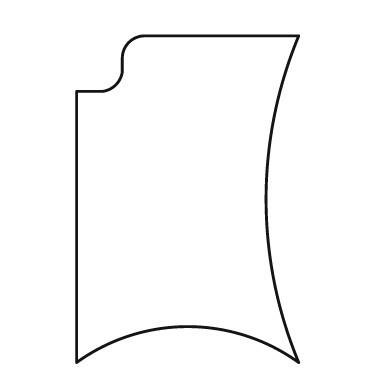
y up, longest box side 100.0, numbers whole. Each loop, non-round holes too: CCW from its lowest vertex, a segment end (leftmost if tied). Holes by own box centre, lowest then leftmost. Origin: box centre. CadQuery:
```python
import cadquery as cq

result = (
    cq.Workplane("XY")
    .moveTo(-34.0, -50.0)
    .threePointArc((0.0, -39.0), (34.0, -50.0))
    .threePointArc((24.0, 0.0), (34.0, 50.0))
    .lineTo(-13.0, 50.0)
    .threePointArc((-18.0, 48.0), (-20.0, 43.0))
    .lineTo(-20.0, 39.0)
    .threePointArc((-22.0, 35.0), (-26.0, 33.0))
    .lineTo(-34.0, 33.0)
    .close()
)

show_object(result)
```